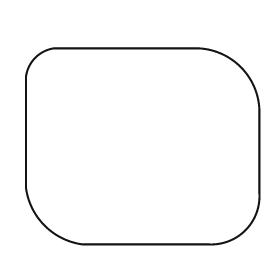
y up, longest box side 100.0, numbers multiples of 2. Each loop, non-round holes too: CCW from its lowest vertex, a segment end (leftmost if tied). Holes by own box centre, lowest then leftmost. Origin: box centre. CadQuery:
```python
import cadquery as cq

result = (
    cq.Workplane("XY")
    .moveTo(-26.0, -42.0)
    .lineTo(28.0, -42.0)
    .threePointArc((44.0, -36.0), (50.0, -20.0))
    .lineTo(50.0, 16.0)
    .threePointArc((42.0, 34.0), (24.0, 42.0))
    .lineTo(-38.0, 42.0)
    .threePointArc((-46.0, 38.0), (-50.0, 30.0))
    .lineTo(-50.0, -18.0)
    .threePointArc((-42.0, -34.0), (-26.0, -42.0))
    .close()
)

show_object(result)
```